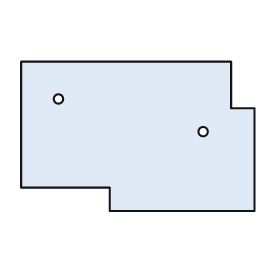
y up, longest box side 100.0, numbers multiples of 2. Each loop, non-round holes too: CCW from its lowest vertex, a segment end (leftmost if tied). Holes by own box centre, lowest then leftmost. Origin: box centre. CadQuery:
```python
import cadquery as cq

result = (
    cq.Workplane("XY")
    .moveTo(-12.0, -32.0)
    .lineTo(50.0, -32.0)
    .lineTo(50.0, 12.0)
    .lineTo(40.0, 12.0)
    .lineTo(40.0, 32.0)
    .lineTo(-50.0, 32.0)
    .lineTo(-50.0, -22.0)
    .lineTo(-12.0, -22.0)
    .close()
    .moveTo(28.0, 2.0)
    .circle(2.0)
    .moveTo(-34.0, 16.0)
    .circle(2.0)
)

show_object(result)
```